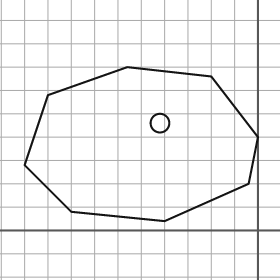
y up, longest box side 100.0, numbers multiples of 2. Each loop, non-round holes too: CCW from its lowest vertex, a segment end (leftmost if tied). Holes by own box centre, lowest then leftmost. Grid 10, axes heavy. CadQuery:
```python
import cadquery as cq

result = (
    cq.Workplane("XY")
    .moveTo(-40.0, 4.0)
    .lineTo(-4.0, 20.0)
    .lineTo(0.0, 40.0)
    .lineTo(-20.0, 66.0)
    .lineTo(-56.0, 70.0)
    .lineTo(-90.0, 58.0)
    .lineTo(-100.0, 28.0)
    .lineTo(-80.0, 8.0)
    .close()
    .moveTo(-42.0, 46.0)
    .circle(4.0)
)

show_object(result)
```